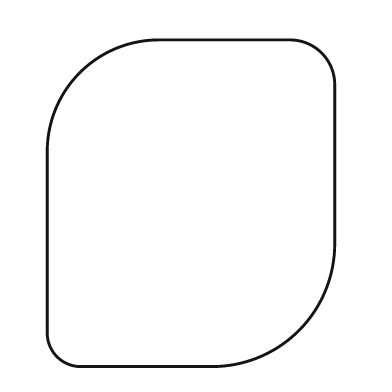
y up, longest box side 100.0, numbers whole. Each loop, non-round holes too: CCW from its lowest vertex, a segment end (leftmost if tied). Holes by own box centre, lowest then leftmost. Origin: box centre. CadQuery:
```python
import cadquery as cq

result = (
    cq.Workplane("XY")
    .moveTo(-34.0, -50.0)
    .lineTo(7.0, -50.0)
    .threePointArc((33.0, -39.0), (44.0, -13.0))
    .lineTo(44.0, 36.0)
    .threePointArc((40.0, 46.0), (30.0, 50.0))
    .lineTo(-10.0, 50.0)
    .threePointArc((-34.0, 40.0), (-44.0, 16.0))
    .lineTo(-44.0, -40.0)
    .threePointArc((-41.0, -47.0), (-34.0, -50.0))
    .close()
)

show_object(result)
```